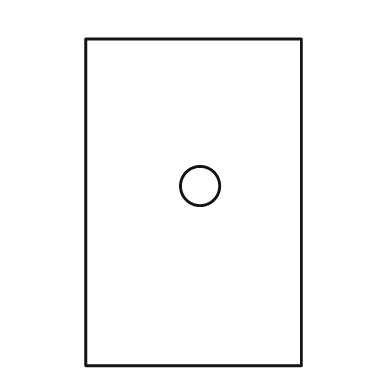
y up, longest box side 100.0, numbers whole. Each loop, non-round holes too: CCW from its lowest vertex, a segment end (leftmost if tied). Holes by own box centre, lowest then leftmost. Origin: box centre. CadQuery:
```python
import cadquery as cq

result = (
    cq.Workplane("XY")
    .moveTo(-33.0, -50.0)
    .lineTo(33.0, -50.0)
    .lineTo(33.0, 50.0)
    .lineTo(-33.0, 50.0)
    .close()
    .moveTo(2.0, 5.0)
    .circle(6.0)
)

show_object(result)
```